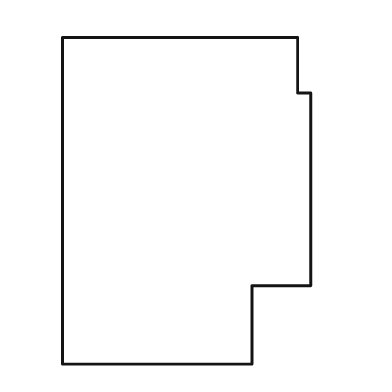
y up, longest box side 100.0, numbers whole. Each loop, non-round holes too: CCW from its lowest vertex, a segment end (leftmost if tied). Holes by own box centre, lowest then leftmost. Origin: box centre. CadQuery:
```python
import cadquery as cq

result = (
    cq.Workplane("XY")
    .moveTo(-38.0, -50.0)
    .lineTo(20.0, -50.0)
    .lineTo(20.0, -26.0)
    .lineTo(38.0, -26.0)
    .lineTo(38.0, 33.0)
    .lineTo(34.0, 33.0)
    .lineTo(34.0, 50.0)
    .lineTo(-38.0, 50.0)
    .close()
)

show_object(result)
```